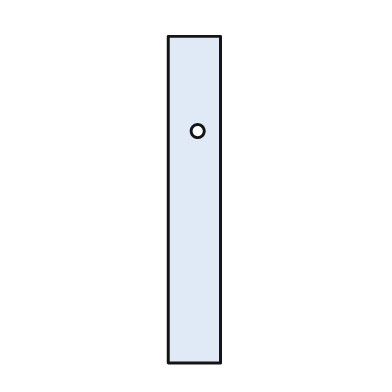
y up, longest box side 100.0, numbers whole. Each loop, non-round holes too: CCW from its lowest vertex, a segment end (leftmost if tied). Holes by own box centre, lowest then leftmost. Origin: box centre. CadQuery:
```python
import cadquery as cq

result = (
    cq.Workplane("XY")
    .moveTo(-8.0, -50.0)
    .lineTo(8.0, -50.0)
    .lineTo(8.0, 50.0)
    .lineTo(-8.0, 50.0)
    .close()
    .moveTo(1.0, 21.0)
    .circle(2.0)
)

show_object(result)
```